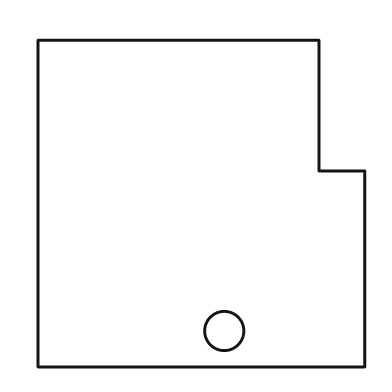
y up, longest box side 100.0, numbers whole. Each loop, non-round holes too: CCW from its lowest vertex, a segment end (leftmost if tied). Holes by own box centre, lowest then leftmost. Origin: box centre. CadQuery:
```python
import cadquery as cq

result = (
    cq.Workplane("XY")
    .moveTo(-50.0, -50.0)
    .lineTo(50.0, -50.0)
    .lineTo(50.0, 10.0)
    .lineTo(36.0, 10.0)
    .lineTo(36.0, 50.0)
    .lineTo(-50.0, 50.0)
    .close()
    .moveTo(7.0, -39.0)
    .circle(6.0)
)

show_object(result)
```